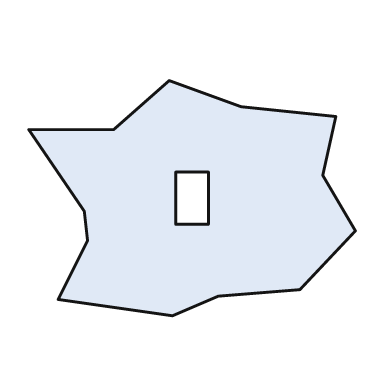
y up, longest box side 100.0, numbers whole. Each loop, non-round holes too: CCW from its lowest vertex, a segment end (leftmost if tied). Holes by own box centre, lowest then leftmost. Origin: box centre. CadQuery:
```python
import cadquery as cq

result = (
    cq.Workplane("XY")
    .moveTo(-6.0, -36.0)
    .lineTo(8.0, -30.0)
    .lineTo(33.0, -28.0)
    .lineTo(50.0, -10.0)
    .lineTo(40.0, 7.0)
    .lineTo(44.0, 25.0)
    .lineTo(15.0, 28.0)
    .lineTo(-7.0, 36.0)
    .lineTo(-24.0, 21.0)
    .lineTo(-50.0, 21.0)
    .lineTo(-33.0, -4.0)
    .lineTo(-32.0, -13.0)
    .lineTo(-41.0, -31.0)
    .close()
    .moveTo(-5.0, -8.0)
    .lineTo(5.0, -8.0)
    .lineTo(5.0, 8.0)
    .lineTo(-5.0, 8.0)
    .close()
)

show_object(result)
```